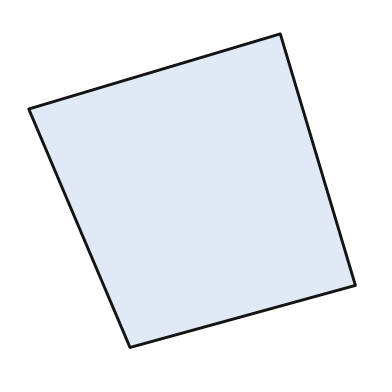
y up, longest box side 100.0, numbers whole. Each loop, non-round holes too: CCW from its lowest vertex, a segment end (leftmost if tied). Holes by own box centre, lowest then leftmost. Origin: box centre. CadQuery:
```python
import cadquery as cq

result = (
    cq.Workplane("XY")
    .moveTo(-19.0, -48.0)
    .lineTo(50.0, -29.0)
    .lineTo(27.0, 48.0)
    .lineTo(-50.0, 25.0)
    .close()
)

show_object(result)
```